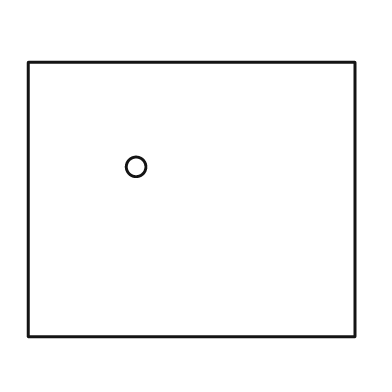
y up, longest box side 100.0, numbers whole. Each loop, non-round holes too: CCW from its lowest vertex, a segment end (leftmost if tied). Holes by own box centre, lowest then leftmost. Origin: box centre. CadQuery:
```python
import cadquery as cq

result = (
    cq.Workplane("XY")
    .moveTo(-50.0, -42.0)
    .lineTo(50.0, -42.0)
    .lineTo(50.0, 42.0)
    .lineTo(-50.0, 42.0)
    .close()
    .moveTo(-17.0, 10.0)
    .circle(3.0)
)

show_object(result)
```